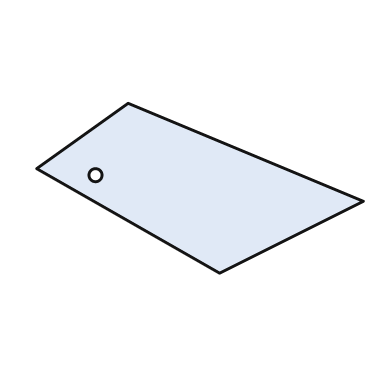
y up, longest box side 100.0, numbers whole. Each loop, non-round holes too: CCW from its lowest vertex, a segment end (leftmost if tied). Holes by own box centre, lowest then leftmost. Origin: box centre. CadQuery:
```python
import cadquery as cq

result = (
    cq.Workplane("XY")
    .moveTo(6.0, -26.0)
    .lineTo(50.0, -4.0)
    .lineTo(-22.0, 26.0)
    .lineTo(-50.0, 6.0)
    .close()
    .moveTo(-32.0, 4.0)
    .circle(2.0)
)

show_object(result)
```